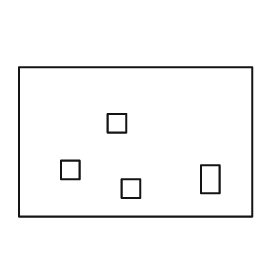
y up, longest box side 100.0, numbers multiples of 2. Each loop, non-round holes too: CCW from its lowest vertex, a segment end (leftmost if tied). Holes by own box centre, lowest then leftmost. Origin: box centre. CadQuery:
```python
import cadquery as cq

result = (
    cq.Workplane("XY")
    .moveTo(-50.0, -32.0)
    .lineTo(50.0, -32.0)
    .lineTo(50.0, 32.0)
    .lineTo(-50.0, 32.0)
    .close()
    .moveTo(-6.0, -24.0)
    .lineTo(2.0, -24.0)
    .lineTo(2.0, -16.0)
    .lineTo(-6.0, -16.0)
    .close()
    .moveTo(28.0, -22.0)
    .lineTo(36.0, -22.0)
    .lineTo(36.0, -10.0)
    .lineTo(28.0, -10.0)
    .close()
    .moveTo(-32.0, -16.0)
    .lineTo(-24.0, -16.0)
    .lineTo(-24.0, -8.0)
    .lineTo(-32.0, -8.0)
    .close()
    .moveTo(-12.0, 4.0)
    .lineTo(-4.0, 4.0)
    .lineTo(-4.0, 12.0)
    .lineTo(-12.0, 12.0)
    .close()
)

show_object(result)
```